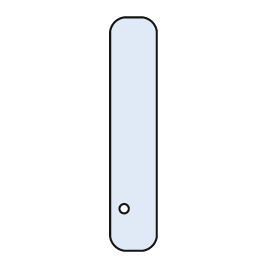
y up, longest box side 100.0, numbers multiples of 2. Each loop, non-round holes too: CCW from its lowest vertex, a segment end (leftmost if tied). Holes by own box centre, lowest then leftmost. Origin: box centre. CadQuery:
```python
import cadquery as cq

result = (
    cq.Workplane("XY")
    .moveTo(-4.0, -50.0)
    .lineTo(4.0, -50.0)
    .threePointArc((8.0, -48.0), (10.0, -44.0))
    .lineTo(10.0, 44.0)
    .threePointArc((8.0, 48.0), (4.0, 50.0))
    .lineTo(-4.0, 50.0)
    .threePointArc((-8.0, 48.0), (-10.0, 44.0))
    .lineTo(-10.0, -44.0)
    .threePointArc((-8.0, -48.0), (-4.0, -50.0))
    .close()
    .moveTo(-4.0, -32.0)
    .circle(2.0)
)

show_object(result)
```